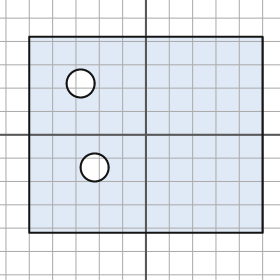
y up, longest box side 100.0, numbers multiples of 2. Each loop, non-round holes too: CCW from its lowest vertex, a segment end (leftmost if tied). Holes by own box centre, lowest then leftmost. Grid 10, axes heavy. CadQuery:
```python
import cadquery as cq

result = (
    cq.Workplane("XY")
    .moveTo(-50.0, -42.0)
    .lineTo(50.0, -42.0)
    .lineTo(50.0, 42.0)
    .lineTo(-50.0, 42.0)
    .close()
    .moveTo(-22.0, -14.0)
    .circle(6.0)
    .moveTo(-28.0, 22.0)
    .circle(6.0)
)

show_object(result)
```